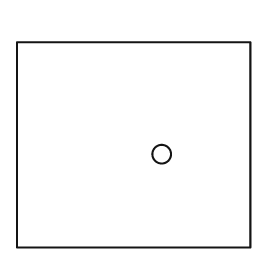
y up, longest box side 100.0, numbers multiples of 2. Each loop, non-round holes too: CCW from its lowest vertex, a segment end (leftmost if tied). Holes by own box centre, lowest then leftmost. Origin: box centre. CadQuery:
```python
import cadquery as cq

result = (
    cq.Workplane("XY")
    .moveTo(-50.0, -44.0)
    .lineTo(50.0, -44.0)
    .lineTo(50.0, 44.0)
    .lineTo(-50.0, 44.0)
    .close()
    .moveTo(12.0, -4.0)
    .circle(4.0)
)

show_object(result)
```